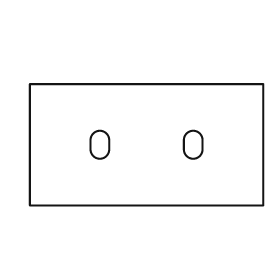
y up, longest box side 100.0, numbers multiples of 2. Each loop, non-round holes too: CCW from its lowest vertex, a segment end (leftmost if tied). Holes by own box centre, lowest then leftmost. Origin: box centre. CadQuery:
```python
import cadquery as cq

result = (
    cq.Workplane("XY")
    .moveTo(-50.0, -26.0)
    .lineTo(50.0, -26.0)
    .lineTo(50.0, 26.0)
    .lineTo(-50.0, 26.0)
    .close()
    .moveTo(-24.0, -2.0)
    .threePointArc((-20.0, -6.0), (-16.0, -2.0))
    .lineTo(-16.0, 2.0)
    .threePointArc((-20.0, 6.0), (-24.0, 2.0))
    .close()
    .moveTo(16.0, -2.0)
    .threePointArc((20.0, -6.0), (24.0, -2.0))
    .lineTo(24.0, 2.0)
    .threePointArc((20.0, 6.0), (16.0, 2.0))
    .close()
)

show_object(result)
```